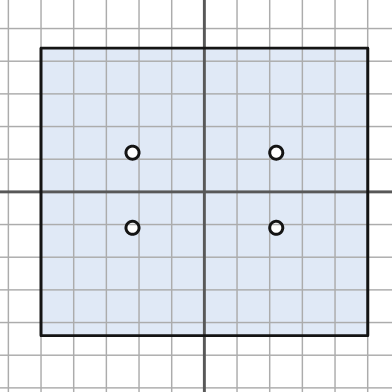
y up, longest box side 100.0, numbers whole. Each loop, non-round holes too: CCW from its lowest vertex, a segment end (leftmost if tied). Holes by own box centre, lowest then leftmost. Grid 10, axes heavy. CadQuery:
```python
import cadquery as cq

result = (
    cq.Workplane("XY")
    .moveTo(-50.0, -44.0)
    .lineTo(50.0, -44.0)
    .lineTo(50.0, 44.0)
    .lineTo(-50.0, 44.0)
    .close()
    .moveTo(-22.0, -11.0)
    .circle(2.0)
    .moveTo(22.0, -11.0)
    .circle(2.0)
    .moveTo(-22.0, 12.0)
    .circle(2.0)
    .moveTo(22.0, 12.0)
    .circle(2.0)
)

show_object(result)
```